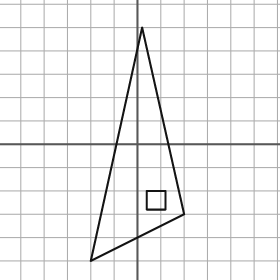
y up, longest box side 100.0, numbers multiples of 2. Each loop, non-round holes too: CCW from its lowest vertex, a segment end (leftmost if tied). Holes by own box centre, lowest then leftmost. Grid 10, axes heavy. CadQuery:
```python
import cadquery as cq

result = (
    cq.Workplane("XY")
    .moveTo(-20.0, -50.0)
    .lineTo(20.0, -30.0)
    .lineTo(2.0, 50.0)
    .close()
    .moveTo(4.0, -28.0)
    .lineTo(12.0, -28.0)
    .lineTo(12.0, -20.0)
    .lineTo(4.0, -20.0)
    .close()
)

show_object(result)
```